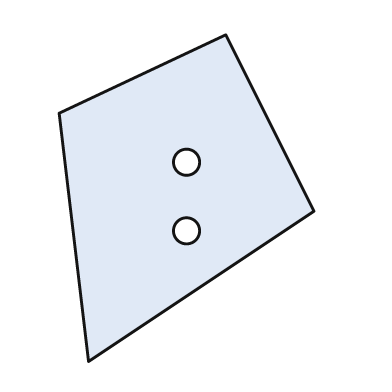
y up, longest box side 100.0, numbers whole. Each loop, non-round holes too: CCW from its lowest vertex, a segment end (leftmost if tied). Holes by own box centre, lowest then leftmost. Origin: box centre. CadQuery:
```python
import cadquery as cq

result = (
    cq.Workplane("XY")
    .moveTo(-30.0, -50.0)
    .lineTo(39.0, -4.0)
    .lineTo(12.0, 50.0)
    .lineTo(-39.0, 26.0)
    .close()
    .moveTo(0.0, -10.0)
    .circle(4.0)
    .moveTo(0.0, 11.0)
    .circle(4.0)
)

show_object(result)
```